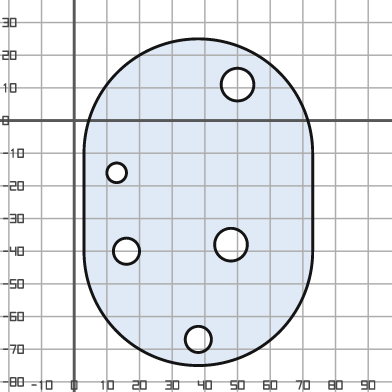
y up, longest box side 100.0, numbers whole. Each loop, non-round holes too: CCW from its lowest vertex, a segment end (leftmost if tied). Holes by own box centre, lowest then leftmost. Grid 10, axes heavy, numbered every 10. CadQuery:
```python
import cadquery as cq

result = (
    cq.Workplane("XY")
    .moveTo(3.0, -40.0)
    .threePointArc((38.0, -75.0), (73.0, -40.0))
    .lineTo(73.0, -10.0)
    .threePointArc((38.0, 25.0), (3.0, -10.0))
    .close()
    .moveTo(38.0, -67.0)
    .circle(4.0)
    .moveTo(16.0, -40.0)
    .circle(4.0)
    .moveTo(48.0, -38.0)
    .circle(5.0)
    .moveTo(13.0, -16.0)
    .circle(3.0)
    .moveTo(50.0, 11.0)
    .circle(5.0)
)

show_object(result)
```